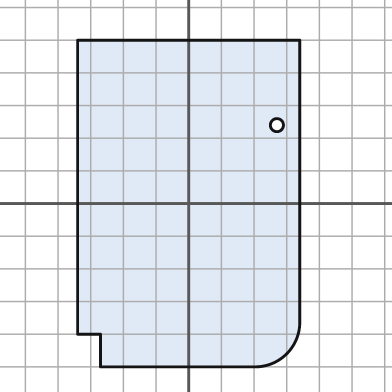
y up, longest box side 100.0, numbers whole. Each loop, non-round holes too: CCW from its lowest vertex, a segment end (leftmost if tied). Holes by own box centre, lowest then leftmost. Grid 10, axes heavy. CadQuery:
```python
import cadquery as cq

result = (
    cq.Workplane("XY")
    .moveTo(-27.0, -50.0)
    .lineTo(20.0, -50.0)
    .threePointArc((30.0, -46.0), (34.0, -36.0))
    .lineTo(34.0, 50.0)
    .lineTo(-34.0, 50.0)
    .lineTo(-34.0, -40.0)
    .lineTo(-27.0, -40.0)
    .close()
    .moveTo(27.0, 24.0)
    .circle(2.0)
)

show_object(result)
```